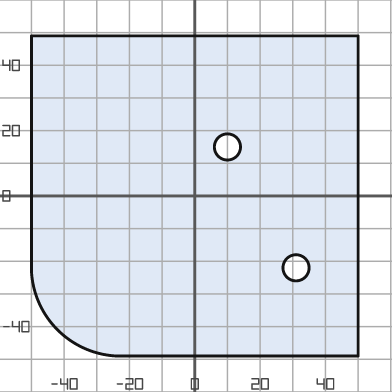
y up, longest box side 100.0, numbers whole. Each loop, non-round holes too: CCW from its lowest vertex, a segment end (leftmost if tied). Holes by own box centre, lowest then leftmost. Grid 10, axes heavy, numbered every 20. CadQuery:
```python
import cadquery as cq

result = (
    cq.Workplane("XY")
    .moveTo(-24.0, -49.0)
    .lineTo(50.0, -49.0)
    .lineTo(50.0, 49.0)
    .lineTo(-50.0, 49.0)
    .lineTo(-50.0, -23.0)
    .threePointArc((-42.0, -41.0), (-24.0, -49.0))
    .close()
    .moveTo(31.0, -22.0)
    .circle(4.0)
    .moveTo(10.0, 15.0)
    .circle(4.0)
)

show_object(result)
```